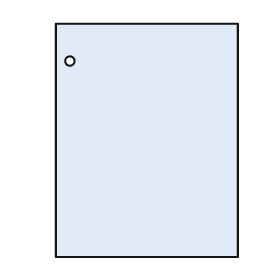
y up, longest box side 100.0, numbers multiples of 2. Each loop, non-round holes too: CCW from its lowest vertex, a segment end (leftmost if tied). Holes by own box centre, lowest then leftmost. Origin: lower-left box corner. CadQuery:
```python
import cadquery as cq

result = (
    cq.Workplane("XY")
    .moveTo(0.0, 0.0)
    .lineTo(78.0, 0.0)
    .lineTo(78.0, 100.0)
    .lineTo(0.0, 100.0)
    .close()
    .moveTo(6.0, 84.0)
    .circle(2.0)
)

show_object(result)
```